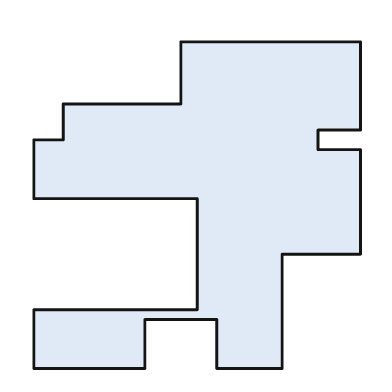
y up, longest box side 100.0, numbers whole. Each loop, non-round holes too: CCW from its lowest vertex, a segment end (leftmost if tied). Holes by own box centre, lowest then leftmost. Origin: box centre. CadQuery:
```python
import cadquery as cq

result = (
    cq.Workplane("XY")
    .moveTo(-50.0, -50.0)
    .lineTo(-16.0, -50.0)
    .lineTo(-16.0, -35.0)
    .lineTo(6.0, -35.0)
    .lineTo(6.0, -50.0)
    .lineTo(26.0, -50.0)
    .lineTo(26.0, -15.0)
    .lineTo(50.0, -15.0)
    .lineTo(50.0, 17.0)
    .lineTo(37.0, 17.0)
    .lineTo(37.0, 23.0)
    .lineTo(50.0, 23.0)
    .lineTo(50.0, 50.0)
    .lineTo(-5.0, 50.0)
    .lineTo(-5.0, 31.0)
    .lineTo(-41.0, 31.0)
    .lineTo(-41.0, 20.0)
    .lineTo(-50.0, 20.0)
    .lineTo(-50.0, 2.0)
    .lineTo(0.0, 2.0)
    .lineTo(0.0, -32.0)
    .lineTo(-50.0, -32.0)
    .close()
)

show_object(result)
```